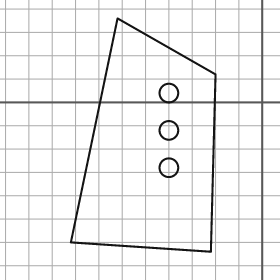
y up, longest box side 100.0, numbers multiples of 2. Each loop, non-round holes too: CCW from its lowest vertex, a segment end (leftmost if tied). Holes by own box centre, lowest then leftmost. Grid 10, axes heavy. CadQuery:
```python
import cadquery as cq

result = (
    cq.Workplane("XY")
    .moveTo(-22.0, -64.0)
    .lineTo(-20.0, 12.0)
    .lineTo(-62.0, 36.0)
    .lineTo(-82.0, -60.0)
    .close()
    .moveTo(-40.0, -28.0)
    .circle(4.0)
    .moveTo(-40.0, -12.0)
    .circle(4.0)
    .moveTo(-40.0, 4.0)
    .circle(4.0)
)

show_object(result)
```